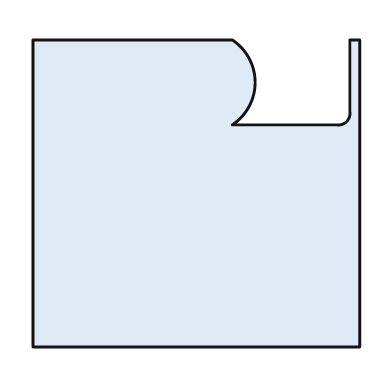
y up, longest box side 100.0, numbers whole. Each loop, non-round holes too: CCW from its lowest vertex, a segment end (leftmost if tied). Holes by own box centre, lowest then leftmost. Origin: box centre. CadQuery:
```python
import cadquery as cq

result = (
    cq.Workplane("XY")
    .moveTo(-50.0, -47.0)
    .lineTo(50.0, -47.0)
    .lineTo(50.0, 47.0)
    .lineTo(47.0, 47.0)
    .lineTo(47.0, 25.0)
    .threePointArc((46.0, 22.0), (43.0, 21.0))
    .lineTo(11.0, 21.0)
    .threePointArc((18.0, 34.0), (11.0, 47.0))
    .lineTo(-50.0, 47.0)
    .close()
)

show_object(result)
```